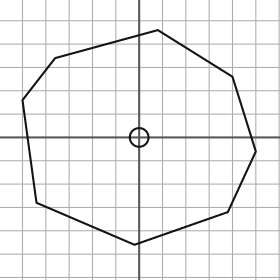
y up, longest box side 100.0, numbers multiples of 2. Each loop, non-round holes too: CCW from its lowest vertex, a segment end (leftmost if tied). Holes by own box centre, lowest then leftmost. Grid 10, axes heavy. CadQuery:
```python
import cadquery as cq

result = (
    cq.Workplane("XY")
    .moveTo(-2.0, -46.0)
    .lineTo(38.0, -32.0)
    .lineTo(50.0, -6.0)
    .lineTo(40.0, 26.0)
    .lineTo(8.0, 46.0)
    .lineTo(-36.0, 34.0)
    .lineTo(-50.0, 16.0)
    .lineTo(-44.0, -28.0)
    .close()
    .moveTo(0.0, 0.0)
    .circle(4.0)
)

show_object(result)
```